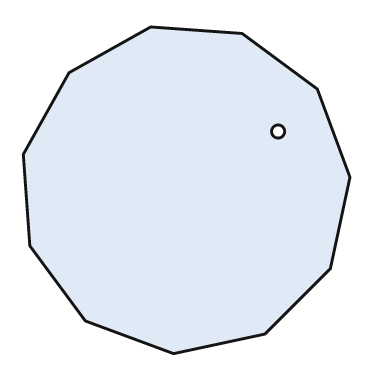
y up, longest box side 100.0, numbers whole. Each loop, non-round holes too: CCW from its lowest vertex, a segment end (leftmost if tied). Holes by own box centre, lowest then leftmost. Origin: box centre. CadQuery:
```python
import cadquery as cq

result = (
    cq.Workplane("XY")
    .moveTo(-4.0, -50.0)
    .lineTo(24.0, -44.0)
    .lineTo(44.0, -24.0)
    .lineTo(50.0, 4.0)
    .lineTo(40.0, 31.0)
    .lineTo(17.0, 48.0)
    .lineTo(-11.0, 50.0)
    .lineTo(-36.0, 36.0)
    .lineTo(-50.0, 11.0)
    .lineTo(-48.0, -17.0)
    .lineTo(-31.0, -40.0)
    .close()
    .moveTo(28.0, 18.0)
    .circle(2.0)
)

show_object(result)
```